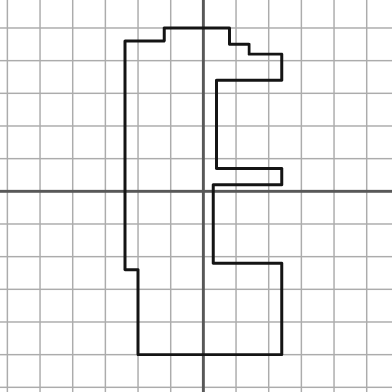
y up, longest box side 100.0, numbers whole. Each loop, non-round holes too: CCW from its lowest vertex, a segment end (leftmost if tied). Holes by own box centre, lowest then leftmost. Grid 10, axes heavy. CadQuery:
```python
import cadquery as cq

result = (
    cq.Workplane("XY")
    .moveTo(-20.0, -50.0)
    .lineTo(24.0, -50.0)
    .lineTo(24.0, -22.0)
    .lineTo(3.0, -22.0)
    .lineTo(3.0, 2.0)
    .lineTo(24.0, 2.0)
    .lineTo(24.0, 7.0)
    .lineTo(4.0, 7.0)
    .lineTo(4.0, 34.0)
    .lineTo(24.0, 34.0)
    .lineTo(24.0, 42.0)
    .lineTo(14.0, 42.0)
    .lineTo(14.0, 45.0)
    .lineTo(8.0, 45.0)
    .lineTo(8.0, 50.0)
    .lineTo(-12.0, 50.0)
    .lineTo(-12.0, 46.0)
    .lineTo(-24.0, 46.0)
    .lineTo(-24.0, -24.0)
    .lineTo(-20.0, -24.0)
    .close()
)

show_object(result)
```